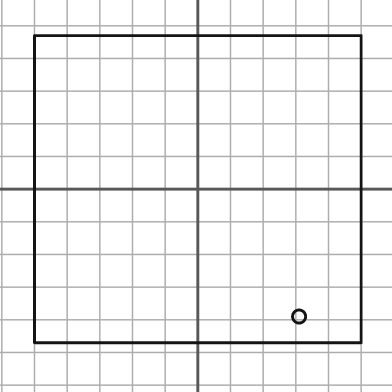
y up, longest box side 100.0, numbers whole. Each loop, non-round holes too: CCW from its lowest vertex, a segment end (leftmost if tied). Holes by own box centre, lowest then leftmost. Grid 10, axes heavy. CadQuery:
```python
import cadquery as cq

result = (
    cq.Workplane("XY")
    .moveTo(-50.0, -47.0)
    .lineTo(50.0, -47.0)
    .lineTo(50.0, 47.0)
    .lineTo(-50.0, 47.0)
    .close()
    .moveTo(31.0, -39.0)
    .circle(2.0)
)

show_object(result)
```